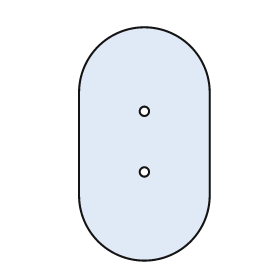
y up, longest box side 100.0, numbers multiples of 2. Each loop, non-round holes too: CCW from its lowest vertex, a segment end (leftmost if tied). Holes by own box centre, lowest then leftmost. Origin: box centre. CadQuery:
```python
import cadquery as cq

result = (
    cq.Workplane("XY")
    .moveTo(-28.0, -22.0)
    .threePointArc((0.0, -50.0), (28.0, -22.0))
    .lineTo(28.0, 22.0)
    .threePointArc((0.0, 50.0), (-28.0, 22.0))
    .close()
    .moveTo(0.0, -12.0)
    .circle(2.0)
    .moveTo(0.0, 14.0)
    .circle(2.0)
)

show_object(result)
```